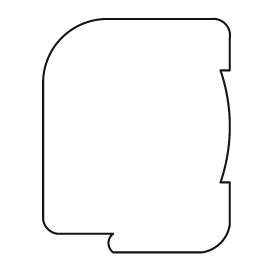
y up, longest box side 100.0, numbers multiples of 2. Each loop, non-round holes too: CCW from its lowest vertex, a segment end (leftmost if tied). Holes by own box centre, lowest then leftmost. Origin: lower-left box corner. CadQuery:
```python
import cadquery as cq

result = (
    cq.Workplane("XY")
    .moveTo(30.0, 0.0)
    .lineTo(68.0, 0.0)
    .threePointArc((76.0, 4.0), (80.0, 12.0))
    .lineTo(80.0, 30.0)
    .lineTo(76.0, 30.0)
    .threePointArc((80.0, 54.0), (76.0, 78.0))
    .lineTo(80.0, 78.0)
    .lineTo(80.0, 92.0)
    .threePointArc((78.0, 98.0), (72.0, 100.0))
    .lineTo(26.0, 100.0)
    .threePointArc((8.0, 92.0), (0.0, 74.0))
    .lineTo(0.0, 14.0)
    .threePointArc((2.0, 10.0), (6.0, 8.0))
    .lineTo(30.0, 8.0)
    .threePointArc((28.0, 4.0), (30.0, 0.0))
    .close()
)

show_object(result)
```